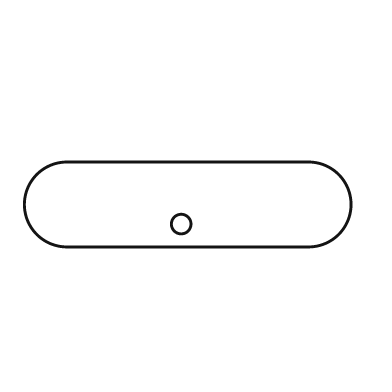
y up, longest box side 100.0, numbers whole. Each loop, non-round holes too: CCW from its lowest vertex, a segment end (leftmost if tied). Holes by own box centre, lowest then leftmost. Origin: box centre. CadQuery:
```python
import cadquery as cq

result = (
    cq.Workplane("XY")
    .moveTo(-37.0, -13.0)
    .lineTo(37.0, -13.0)
    .threePointArc((50.0, 0.0), (37.0, 13.0))
    .lineTo(-37.0, 13.0)
    .threePointArc((-50.0, 0.0), (-37.0, -13.0))
    .close()
    .moveTo(-2.0, -6.0)
    .circle(3.0)
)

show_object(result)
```